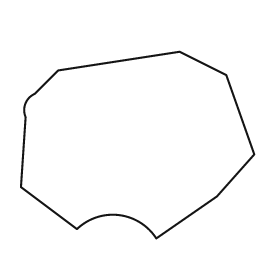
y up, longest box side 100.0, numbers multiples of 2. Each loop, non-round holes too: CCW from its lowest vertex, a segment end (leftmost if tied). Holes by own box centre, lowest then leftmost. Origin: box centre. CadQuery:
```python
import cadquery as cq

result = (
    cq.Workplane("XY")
    .moveTo(8.0, -40.0)
    .lineTo(34.0, -22.0)
    .lineTo(50.0, -4.0)
    .lineTo(38.0, 30.0)
    .lineTo(18.0, 40.0)
    .lineTo(-34.0, 32.0)
    .lineTo(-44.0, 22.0)
    .threePointArc((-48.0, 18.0), (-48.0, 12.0))
    .lineTo(-50.0, -18.0)
    .lineTo(-26.0, -36.0)
    .threePointArc((-8.0, -30.0), (8.0, -40.0))
    .close()
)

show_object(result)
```